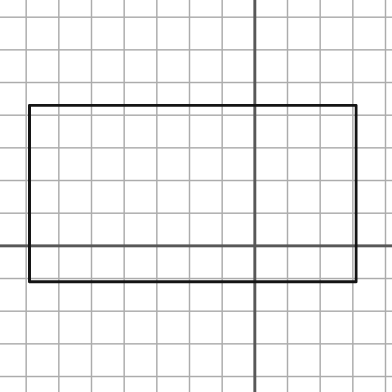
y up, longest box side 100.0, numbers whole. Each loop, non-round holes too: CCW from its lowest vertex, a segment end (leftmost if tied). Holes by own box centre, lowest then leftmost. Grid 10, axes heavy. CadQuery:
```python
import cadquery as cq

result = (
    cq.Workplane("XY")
    .moveTo(-69.0, -11.0)
    .lineTo(31.0, -11.0)
    .lineTo(31.0, 43.0)
    .lineTo(-69.0, 43.0)
    .close()
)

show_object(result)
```